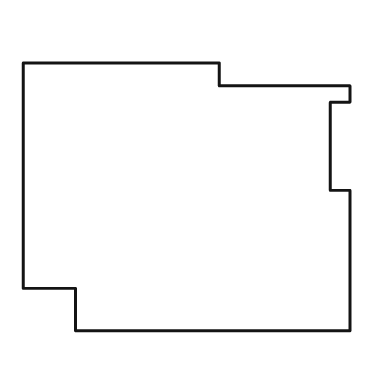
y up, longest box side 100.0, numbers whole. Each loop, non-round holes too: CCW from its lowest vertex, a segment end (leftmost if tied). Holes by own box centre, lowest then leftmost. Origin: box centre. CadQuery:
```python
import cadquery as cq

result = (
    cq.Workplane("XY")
    .moveTo(-34.0, -41.0)
    .lineTo(50.0, -41.0)
    .lineTo(50.0, 2.0)
    .lineTo(44.0, 2.0)
    .lineTo(44.0, 29.0)
    .lineTo(50.0, 29.0)
    .lineTo(50.0, 34.0)
    .lineTo(10.0, 34.0)
    .lineTo(10.0, 41.0)
    .lineTo(-50.0, 41.0)
    .lineTo(-50.0, -28.0)
    .lineTo(-34.0, -28.0)
    .close()
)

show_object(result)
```